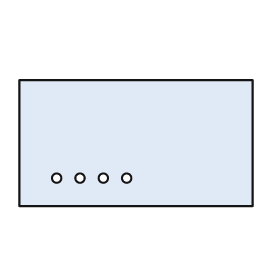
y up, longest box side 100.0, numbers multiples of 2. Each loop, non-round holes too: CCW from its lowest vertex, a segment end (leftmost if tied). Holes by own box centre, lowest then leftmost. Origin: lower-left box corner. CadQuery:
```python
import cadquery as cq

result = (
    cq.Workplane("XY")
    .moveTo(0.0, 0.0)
    .lineTo(100.0, 0.0)
    .lineTo(100.0, 54.0)
    .lineTo(0.0, 54.0)
    .close()
    .moveTo(16.0, 12.0)
    .circle(2.0)
    .moveTo(26.0, 12.0)
    .circle(2.0)
    .moveTo(36.0, 12.0)
    .circle(2.0)
    .moveTo(46.0, 12.0)
    .circle(2.0)
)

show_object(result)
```